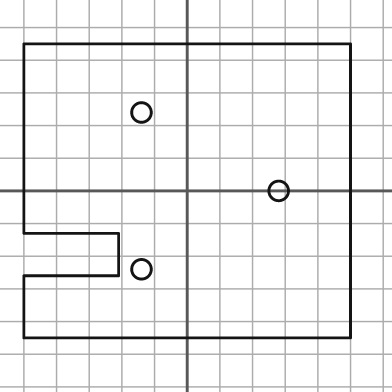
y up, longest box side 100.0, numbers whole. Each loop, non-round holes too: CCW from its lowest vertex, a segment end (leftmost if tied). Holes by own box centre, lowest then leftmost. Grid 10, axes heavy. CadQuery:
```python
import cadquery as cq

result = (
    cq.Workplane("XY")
    .moveTo(-50.0, -45.0)
    .lineTo(50.0, -45.0)
    .lineTo(50.0, 45.0)
    .lineTo(-50.0, 45.0)
    .lineTo(-50.0, -13.0)
    .lineTo(-21.0, -13.0)
    .lineTo(-21.0, -26.0)
    .lineTo(-50.0, -26.0)
    .close()
    .moveTo(-14.0, -24.0)
    .circle(3.0)
    .moveTo(28.0, 0.0)
    .circle(3.0)
    .moveTo(-14.0, 24.0)
    .circle(3.0)
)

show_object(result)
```